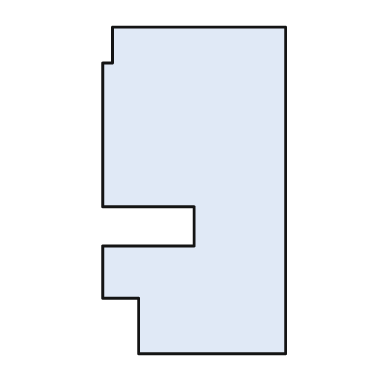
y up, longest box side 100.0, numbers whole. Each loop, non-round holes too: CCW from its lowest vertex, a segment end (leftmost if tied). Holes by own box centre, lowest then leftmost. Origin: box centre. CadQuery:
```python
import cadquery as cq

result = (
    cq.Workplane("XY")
    .moveTo(-17.0, -50.0)
    .lineTo(28.0, -50.0)
    .lineTo(28.0, 50.0)
    .lineTo(-25.0, 50.0)
    .lineTo(-25.0, 39.0)
    .lineTo(-28.0, 39.0)
    .lineTo(-28.0, -5.0)
    .lineTo(0.0, -5.0)
    .lineTo(0.0, -17.0)
    .lineTo(-28.0, -17.0)
    .lineTo(-28.0, -33.0)
    .lineTo(-17.0, -33.0)
    .close()
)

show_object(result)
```